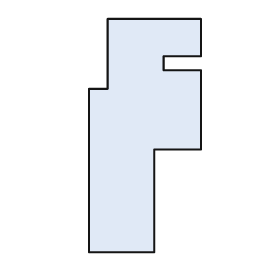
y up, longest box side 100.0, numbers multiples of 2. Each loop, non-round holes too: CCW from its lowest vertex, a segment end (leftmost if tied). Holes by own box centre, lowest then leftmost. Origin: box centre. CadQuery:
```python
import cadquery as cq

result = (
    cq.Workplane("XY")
    .moveTo(-24.0, -50.0)
    .lineTo(4.0, -50.0)
    .lineTo(4.0, -6.0)
    .lineTo(24.0, -6.0)
    .lineTo(24.0, 28.0)
    .lineTo(8.0, 28.0)
    .lineTo(8.0, 34.0)
    .lineTo(24.0, 34.0)
    .lineTo(24.0, 50.0)
    .lineTo(-16.0, 50.0)
    .lineTo(-16.0, 20.0)
    .lineTo(-24.0, 20.0)
    .close()
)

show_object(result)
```